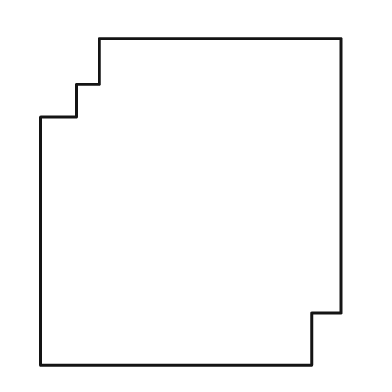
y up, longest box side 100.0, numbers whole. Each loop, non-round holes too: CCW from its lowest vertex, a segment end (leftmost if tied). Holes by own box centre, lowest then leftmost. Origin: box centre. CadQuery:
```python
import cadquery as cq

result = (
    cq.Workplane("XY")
    .moveTo(-46.0, -50.0)
    .lineTo(37.0, -50.0)
    .lineTo(37.0, -34.0)
    .lineTo(46.0, -34.0)
    .lineTo(46.0, 50.0)
    .lineTo(-28.0, 50.0)
    .lineTo(-28.0, 36.0)
    .lineTo(-35.0, 36.0)
    .lineTo(-35.0, 26.0)
    .lineTo(-46.0, 26.0)
    .close()
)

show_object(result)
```